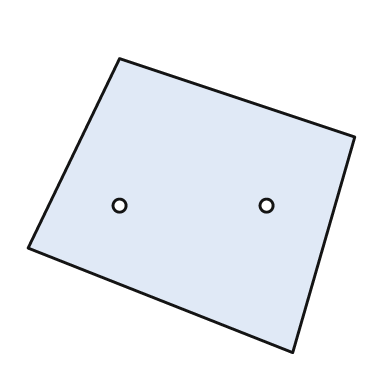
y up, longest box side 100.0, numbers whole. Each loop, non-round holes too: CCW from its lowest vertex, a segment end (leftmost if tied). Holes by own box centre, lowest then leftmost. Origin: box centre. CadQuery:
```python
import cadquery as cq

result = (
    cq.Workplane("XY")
    .moveTo(31.0, -45.0)
    .lineTo(50.0, 21.0)
    .lineTo(-22.0, 45.0)
    .lineTo(-50.0, -13.0)
    .close()
    .moveTo(-22.0, 0.0)
    .circle(2.0)
    .moveTo(23.0, 0.0)
    .circle(2.0)
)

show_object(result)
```